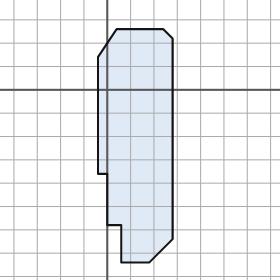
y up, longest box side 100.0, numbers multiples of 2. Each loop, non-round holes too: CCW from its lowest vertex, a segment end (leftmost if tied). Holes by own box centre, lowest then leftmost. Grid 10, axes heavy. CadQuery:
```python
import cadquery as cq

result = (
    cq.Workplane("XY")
    .moveTo(6.0, -74.0)
    .lineTo(18.0, -74.0)
    .lineTo(28.0, -64.0)
    .lineTo(28.0, 22.0)
    .lineTo(24.0, 26.0)
    .lineTo(4.0, 26.0)
    .lineTo(-4.0, 14.0)
    .lineTo(-4.0, -36.0)
    .lineTo(0.0, -36.0)
    .lineTo(0.0, -58.0)
    .lineTo(6.0, -58.0)
    .close()
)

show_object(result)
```